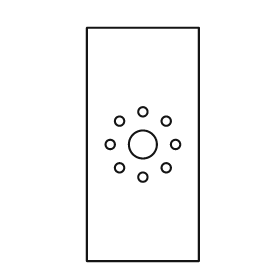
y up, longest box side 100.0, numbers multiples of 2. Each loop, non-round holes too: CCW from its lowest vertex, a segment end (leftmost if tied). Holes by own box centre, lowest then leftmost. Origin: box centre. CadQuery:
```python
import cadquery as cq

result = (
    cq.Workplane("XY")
    .moveTo(-24.0, -50.0)
    .lineTo(24.0, -50.0)
    .lineTo(24.0, 50.0)
    .lineTo(-24.0, 50.0)
    .close()
    .moveTo(0.0, -14.0)
    .circle(2.0)
    .moveTo(-10.0, -10.0)
    .circle(2.0)
    .moveTo(10.0, -10.0)
    .circle(2.0)
    .moveTo(-14.0, 0.0)
    .circle(2.0)
    .moveTo(0.0, 0.0)
    .circle(6.0)
    .moveTo(14.0, 0.0)
    .circle(2.0)
    .moveTo(-10.0, 10.0)
    .circle(2.0)
    .moveTo(10.0, 10.0)
    .circle(2.0)
    .moveTo(0.0, 14.0)
    .circle(2.0)
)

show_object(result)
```